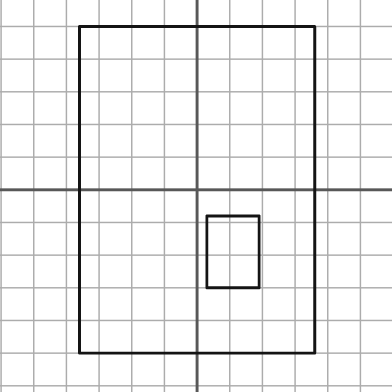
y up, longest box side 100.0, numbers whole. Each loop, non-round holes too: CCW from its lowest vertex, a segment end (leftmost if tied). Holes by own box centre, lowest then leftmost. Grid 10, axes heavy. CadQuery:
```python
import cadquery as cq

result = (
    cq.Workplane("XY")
    .moveTo(-36.0, -50.0)
    .lineTo(36.0, -50.0)
    .lineTo(36.0, 50.0)
    .lineTo(-36.0, 50.0)
    .close()
    .moveTo(3.0, -30.0)
    .lineTo(19.0, -30.0)
    .lineTo(19.0, -8.0)
    .lineTo(3.0, -8.0)
    .close()
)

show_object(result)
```